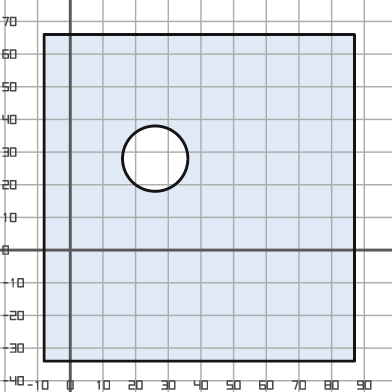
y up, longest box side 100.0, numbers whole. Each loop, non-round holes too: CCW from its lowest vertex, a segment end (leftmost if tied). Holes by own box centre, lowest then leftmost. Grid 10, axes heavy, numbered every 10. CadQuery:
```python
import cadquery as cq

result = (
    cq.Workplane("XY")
    .moveTo(-8.0, -34.0)
    .lineTo(87.0, -34.0)
    .lineTo(87.0, 66.0)
    .lineTo(-8.0, 66.0)
    .close()
    .moveTo(26.0, 28.0)
    .circle(10.0)
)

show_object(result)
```